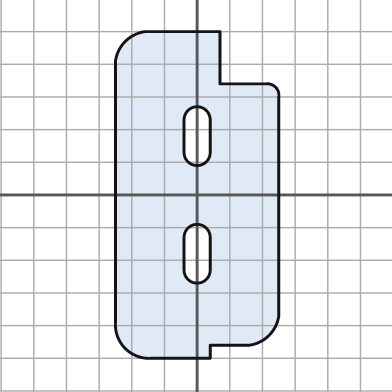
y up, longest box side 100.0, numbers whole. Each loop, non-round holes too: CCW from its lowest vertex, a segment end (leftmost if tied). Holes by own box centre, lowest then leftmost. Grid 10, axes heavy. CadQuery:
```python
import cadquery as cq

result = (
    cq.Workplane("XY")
    .moveTo(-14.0, -50.0)
    .lineTo(4.0, -50.0)
    .lineTo(4.0, -46.0)
    .lineTo(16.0, -46.0)
    .threePointArc((22.0, -43.0), (25.0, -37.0))
    .lineTo(25.0, 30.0)
    .threePointArc((24.0, 33.0), (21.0, 34.0))
    .lineTo(7.0, 34.0)
    .lineTo(7.0, 50.0)
    .lineTo(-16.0, 50.0)
    .threePointArc((-22.0, 47.0), (-25.0, 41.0))
    .lineTo(-25.0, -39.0)
    .threePointArc((-22.0, -47.0), (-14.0, -50.0))
    .close()
    .moveTo(-4.0, -23.0)
    .threePointArc((0.0, -27.0), (4.0, -23.0))
    .lineTo(4.0, -13.0)
    .threePointArc((0.0, -9.0), (-4.0, -13.0))
    .close()
    .moveTo(-4.0, 13.0)
    .threePointArc((0.0, 9.0), (4.0, 13.0))
    .lineTo(4.0, 23.0)
    .threePointArc((0.0, 27.0), (-4.0, 23.0))
    .close()
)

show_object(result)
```